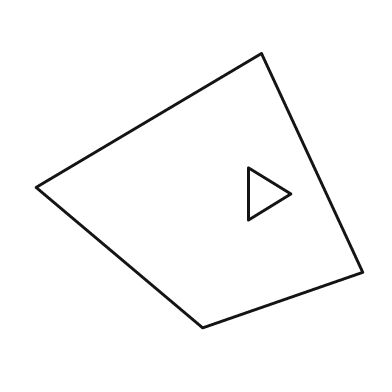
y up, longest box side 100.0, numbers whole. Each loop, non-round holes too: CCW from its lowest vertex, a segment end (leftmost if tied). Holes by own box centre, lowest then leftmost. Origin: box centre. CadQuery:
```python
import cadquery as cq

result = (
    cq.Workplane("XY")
    .moveTo(1.0, -42.0)
    .lineTo(50.0, -25.0)
    .lineTo(19.0, 42.0)
    .lineTo(-50.0, 1.0)
    .close()
    .moveTo(15.0, -9.0)
    .lineTo(28.0, -1.0)
    .lineTo(15.0, 7.0)
    .close()
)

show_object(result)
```